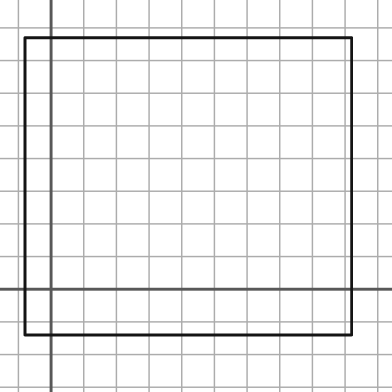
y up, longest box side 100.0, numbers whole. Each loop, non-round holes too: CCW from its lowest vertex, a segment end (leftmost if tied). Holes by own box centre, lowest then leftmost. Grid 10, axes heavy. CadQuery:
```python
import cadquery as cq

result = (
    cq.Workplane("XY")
    .moveTo(-8.0, -14.0)
    .lineTo(92.0, -14.0)
    .lineTo(92.0, 77.0)
    .lineTo(-8.0, 77.0)
    .close()
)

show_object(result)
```